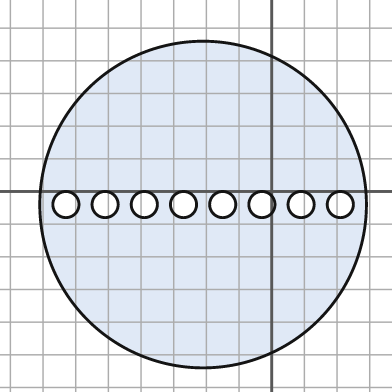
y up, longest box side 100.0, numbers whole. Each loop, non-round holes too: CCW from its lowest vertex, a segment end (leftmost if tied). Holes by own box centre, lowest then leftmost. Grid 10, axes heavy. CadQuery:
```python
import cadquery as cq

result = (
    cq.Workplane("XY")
    .moveTo(-21.0, -4.0)
    .circle(50.0)
    .moveTo(-63.0, -4.0)
    .circle(4.0)
    .moveTo(-51.0, -4.0)
    .circle(4.0)
    .moveTo(-39.0, -4.0)
    .circle(4.0)
    .moveTo(-27.0, -4.0)
    .circle(4.0)
    .moveTo(-15.0, -4.0)
    .circle(4.0)
    .moveTo(-3.0, -4.0)
    .circle(4.0)
    .moveTo(9.0, -4.0)
    .circle(4.0)
    .moveTo(21.0, -4.0)
    .circle(4.0)
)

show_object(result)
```